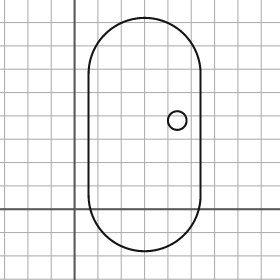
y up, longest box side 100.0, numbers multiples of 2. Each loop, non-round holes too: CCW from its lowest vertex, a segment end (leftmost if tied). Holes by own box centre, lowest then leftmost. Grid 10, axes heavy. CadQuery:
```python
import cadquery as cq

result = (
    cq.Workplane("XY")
    .moveTo(6.0, 6.0)
    .threePointArc((30.0, -18.0), (54.0, 6.0))
    .lineTo(54.0, 58.0)
    .threePointArc((30.0, 82.0), (6.0, 58.0))
    .close()
    .moveTo(44.0, 38.0)
    .circle(4.0)
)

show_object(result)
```